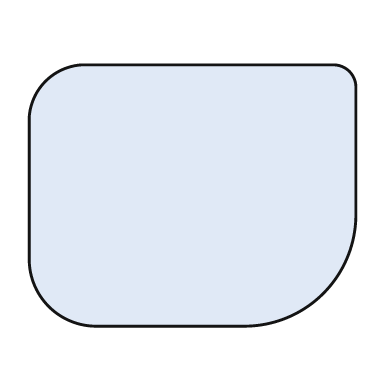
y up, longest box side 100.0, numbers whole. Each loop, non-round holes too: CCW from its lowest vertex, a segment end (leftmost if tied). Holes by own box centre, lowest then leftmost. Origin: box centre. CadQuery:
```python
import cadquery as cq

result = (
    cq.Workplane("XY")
    .moveTo(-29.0, -40.0)
    .lineTo(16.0, -40.0)
    .threePointArc((40.0, -30.0), (50.0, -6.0))
    .lineTo(50.0, 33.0)
    .threePointArc((48.0, 38.0), (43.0, 40.0))
    .lineTo(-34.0, 40.0)
    .threePointArc((-45.0, 35.0), (-50.0, 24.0))
    .lineTo(-50.0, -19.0)
    .threePointArc((-44.0, -34.0), (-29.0, -40.0))
    .close()
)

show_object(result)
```